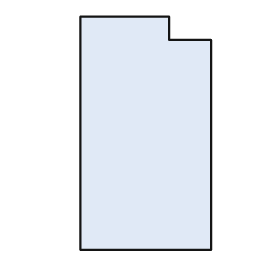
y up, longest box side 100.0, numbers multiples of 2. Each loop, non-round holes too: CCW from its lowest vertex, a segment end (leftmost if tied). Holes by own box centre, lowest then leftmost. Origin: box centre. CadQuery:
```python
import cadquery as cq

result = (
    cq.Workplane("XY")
    .moveTo(-28.0, -50.0)
    .lineTo(28.0, -50.0)
    .lineTo(28.0, 40.0)
    .lineTo(10.0, 40.0)
    .lineTo(10.0, 50.0)
    .lineTo(-28.0, 50.0)
    .close()
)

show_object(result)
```